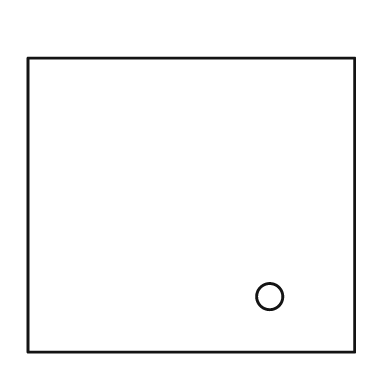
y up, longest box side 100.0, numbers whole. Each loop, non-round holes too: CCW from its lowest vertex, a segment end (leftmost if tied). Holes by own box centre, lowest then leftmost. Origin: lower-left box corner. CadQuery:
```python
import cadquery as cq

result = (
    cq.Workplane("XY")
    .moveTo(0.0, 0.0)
    .lineTo(100.0, 0.0)
    .lineTo(100.0, 90.0)
    .lineTo(0.0, 90.0)
    .close()
    .moveTo(74.0, 17.0)
    .circle(4.0)
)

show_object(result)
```